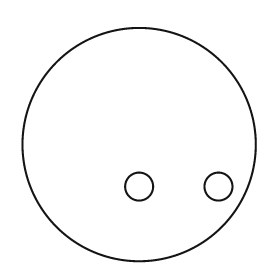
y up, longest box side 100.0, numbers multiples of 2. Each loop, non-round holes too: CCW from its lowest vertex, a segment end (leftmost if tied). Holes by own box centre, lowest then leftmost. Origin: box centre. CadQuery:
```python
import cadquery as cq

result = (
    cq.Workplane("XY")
    .moveTo(0.0, 0.0)
    .circle(50.0)
    .moveTo(0.0, -18.0)
    .circle(6.0)
    .moveTo(34.0, -18.0)
    .circle(6.0)
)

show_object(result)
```